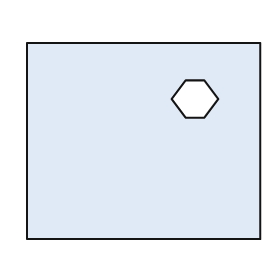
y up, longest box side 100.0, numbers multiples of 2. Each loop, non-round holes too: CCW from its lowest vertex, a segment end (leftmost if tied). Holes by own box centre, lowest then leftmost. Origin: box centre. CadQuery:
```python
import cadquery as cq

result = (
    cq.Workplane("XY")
    .moveTo(-50.0, -42.0)
    .lineTo(50.0, -42.0)
    .lineTo(50.0, 42.0)
    .lineTo(-50.0, 42.0)
    .close()
    .moveTo(18.0, 10.0)
    .lineTo(26.0, 10.0)
    .lineTo(32.0, 18.0)
    .lineTo(26.0, 26.0)
    .lineTo(18.0, 26.0)
    .lineTo(12.0, 18.0)
    .close()
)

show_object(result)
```